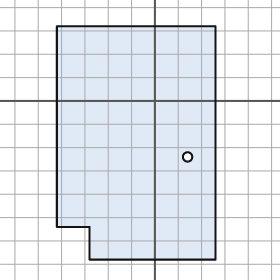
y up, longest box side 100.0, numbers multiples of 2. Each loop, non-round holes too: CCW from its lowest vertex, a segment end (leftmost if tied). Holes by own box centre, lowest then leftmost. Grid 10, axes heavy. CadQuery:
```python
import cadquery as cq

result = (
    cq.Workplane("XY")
    .moveTo(-28.0, -68.0)
    .lineTo(26.0, -68.0)
    .lineTo(26.0, 32.0)
    .lineTo(-42.0, 32.0)
    .lineTo(-42.0, -54.0)
    .lineTo(-28.0, -54.0)
    .close()
    .moveTo(14.0, -24.0)
    .circle(2.0)
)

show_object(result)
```